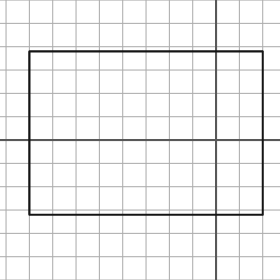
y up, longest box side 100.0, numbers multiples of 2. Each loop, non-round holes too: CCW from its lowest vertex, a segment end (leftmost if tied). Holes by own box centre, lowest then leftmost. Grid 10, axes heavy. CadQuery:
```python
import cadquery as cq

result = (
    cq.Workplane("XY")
    .moveTo(-80.0, -32.0)
    .lineTo(20.0, -32.0)
    .lineTo(20.0, 38.0)
    .lineTo(-80.0, 38.0)
    .close()
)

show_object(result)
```